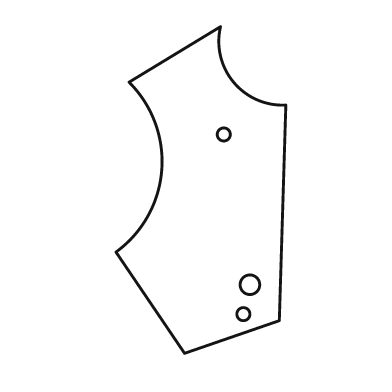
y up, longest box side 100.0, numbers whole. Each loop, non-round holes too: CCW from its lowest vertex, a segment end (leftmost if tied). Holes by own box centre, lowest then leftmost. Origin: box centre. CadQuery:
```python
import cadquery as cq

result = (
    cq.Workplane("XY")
    .moveTo(-5.0, -50.0)
    .lineTo(24.0, -40.0)
    .lineTo(26.0, 26.0)
    .threePointArc((10.0, 33.0), (6.0, 50.0))
    .lineTo(-22.0, 33.0)
    .threePointArc((-12.0, 6.0), (-26.0, -19.0))
    .close()
    .moveTo(13.0, -38.0)
    .circle(2.0)
    .moveTo(15.0, -29.0)
    .circle(3.0)
    .moveTo(7.0, 17.0)
    .circle(2.0)
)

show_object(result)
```